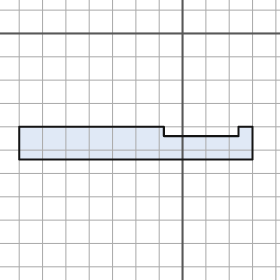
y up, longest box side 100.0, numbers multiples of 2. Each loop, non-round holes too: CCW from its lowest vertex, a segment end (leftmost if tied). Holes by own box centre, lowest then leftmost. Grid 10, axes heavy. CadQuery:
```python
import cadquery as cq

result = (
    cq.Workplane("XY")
    .moveTo(-70.0, -54.0)
    .lineTo(30.0, -54.0)
    .lineTo(30.0, -40.0)
    .lineTo(24.0, -40.0)
    .lineTo(24.0, -44.0)
    .lineTo(-8.0, -44.0)
    .lineTo(-8.0, -40.0)
    .lineTo(-70.0, -40.0)
    .close()
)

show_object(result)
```